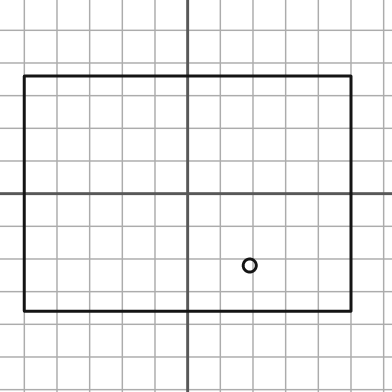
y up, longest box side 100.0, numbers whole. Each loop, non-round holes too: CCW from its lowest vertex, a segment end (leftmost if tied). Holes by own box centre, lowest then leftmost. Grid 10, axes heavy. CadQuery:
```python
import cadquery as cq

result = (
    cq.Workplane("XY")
    .moveTo(-50.0, -36.0)
    .lineTo(50.0, -36.0)
    .lineTo(50.0, 36.0)
    .lineTo(-50.0, 36.0)
    .close()
    .moveTo(19.0, -22.0)
    .circle(2.0)
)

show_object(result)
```